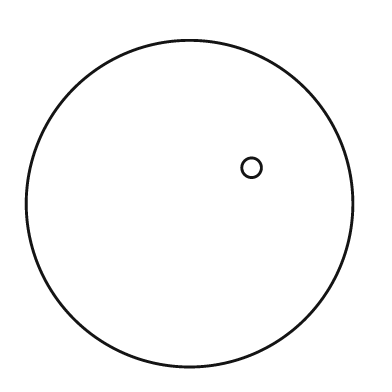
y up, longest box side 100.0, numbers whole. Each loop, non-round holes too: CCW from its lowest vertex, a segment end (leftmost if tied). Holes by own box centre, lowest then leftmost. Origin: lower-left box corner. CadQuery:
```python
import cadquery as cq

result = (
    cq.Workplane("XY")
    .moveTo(50.0, 50.0)
    .circle(50.0)
    .moveTo(69.0, 61.0)
    .circle(3.0)
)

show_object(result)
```